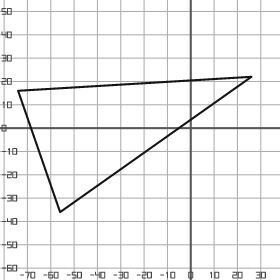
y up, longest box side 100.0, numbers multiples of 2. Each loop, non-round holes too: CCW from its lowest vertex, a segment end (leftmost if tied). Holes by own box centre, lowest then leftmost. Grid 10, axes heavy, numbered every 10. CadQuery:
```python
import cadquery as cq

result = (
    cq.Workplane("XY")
    .moveTo(-56.0, -36.0)
    .lineTo(26.0, 22.0)
    .lineTo(-74.0, 16.0)
    .close()
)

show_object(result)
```